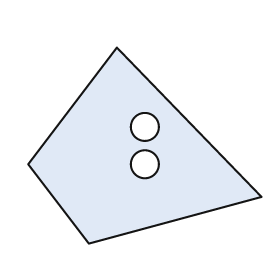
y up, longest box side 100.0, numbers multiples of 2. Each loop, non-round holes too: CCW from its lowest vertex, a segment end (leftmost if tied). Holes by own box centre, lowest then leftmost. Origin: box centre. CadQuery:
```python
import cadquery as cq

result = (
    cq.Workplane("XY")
    .moveTo(-24.0, -42.0)
    .lineTo(50.0, -22.0)
    .lineTo(-12.0, 42.0)
    .lineTo(-50.0, -8.0)
    .close()
    .moveTo(0.0, -8.0)
    .circle(6.0)
    .moveTo(0.0, 8.0)
    .circle(6.0)
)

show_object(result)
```